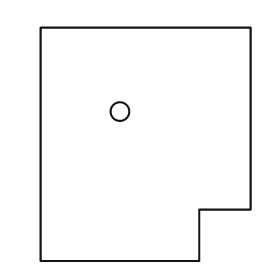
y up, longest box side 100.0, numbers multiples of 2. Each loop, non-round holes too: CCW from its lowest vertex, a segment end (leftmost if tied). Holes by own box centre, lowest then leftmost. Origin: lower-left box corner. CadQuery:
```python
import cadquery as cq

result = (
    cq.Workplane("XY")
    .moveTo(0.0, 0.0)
    .lineTo(68.0, 0.0)
    .lineTo(68.0, 22.0)
    .lineTo(90.0, 22.0)
    .lineTo(90.0, 100.0)
    .lineTo(0.0, 100.0)
    .close()
    .moveTo(34.0, 64.0)
    .circle(4.0)
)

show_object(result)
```